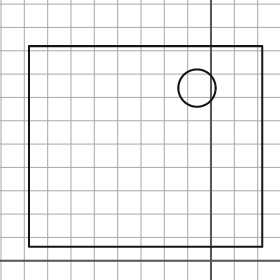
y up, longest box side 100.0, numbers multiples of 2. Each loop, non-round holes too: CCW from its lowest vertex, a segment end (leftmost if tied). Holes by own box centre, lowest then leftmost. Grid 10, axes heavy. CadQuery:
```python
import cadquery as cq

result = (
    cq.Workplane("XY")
    .moveTo(-78.0, 6.0)
    .lineTo(22.0, 6.0)
    .lineTo(22.0, 92.0)
    .lineTo(-78.0, 92.0)
    .close()
    .moveTo(-6.0, 74.0)
    .circle(8.0)
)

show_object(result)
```